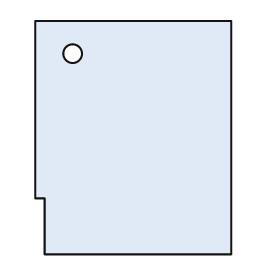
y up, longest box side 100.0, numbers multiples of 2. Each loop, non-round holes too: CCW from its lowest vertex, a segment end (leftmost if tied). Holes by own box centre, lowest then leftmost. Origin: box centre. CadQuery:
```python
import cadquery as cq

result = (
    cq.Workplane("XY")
    .moveTo(-38.0, -50.0)
    .lineTo(42.0, -50.0)
    .lineTo(42.0, 50.0)
    .lineTo(-42.0, 50.0)
    .lineTo(-42.0, -26.0)
    .lineTo(-38.0, -26.0)
    .close()
    .moveTo(-26.0, 36.0)
    .circle(4.0)
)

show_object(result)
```